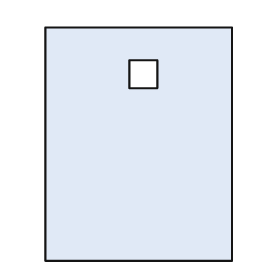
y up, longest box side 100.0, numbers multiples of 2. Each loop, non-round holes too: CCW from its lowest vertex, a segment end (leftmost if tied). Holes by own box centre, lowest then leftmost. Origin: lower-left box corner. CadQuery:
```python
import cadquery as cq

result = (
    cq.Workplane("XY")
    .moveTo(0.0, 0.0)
    .lineTo(80.0, 0.0)
    .lineTo(80.0, 100.0)
    .lineTo(0.0, 100.0)
    .close()
    .moveTo(36.0, 74.0)
    .lineTo(48.0, 74.0)
    .lineTo(48.0, 86.0)
    .lineTo(36.0, 86.0)
    .close()
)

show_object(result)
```